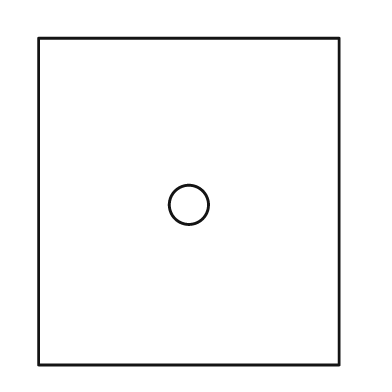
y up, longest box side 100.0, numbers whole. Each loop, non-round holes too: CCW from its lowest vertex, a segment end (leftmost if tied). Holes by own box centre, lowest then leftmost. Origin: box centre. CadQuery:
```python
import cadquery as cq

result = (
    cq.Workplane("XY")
    .moveTo(-46.0, -50.0)
    .lineTo(46.0, -50.0)
    .lineTo(46.0, 50.0)
    .lineTo(-46.0, 50.0)
    .close()
    .moveTo(0.0, -1.0)
    .circle(6.0)
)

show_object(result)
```